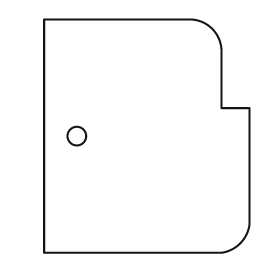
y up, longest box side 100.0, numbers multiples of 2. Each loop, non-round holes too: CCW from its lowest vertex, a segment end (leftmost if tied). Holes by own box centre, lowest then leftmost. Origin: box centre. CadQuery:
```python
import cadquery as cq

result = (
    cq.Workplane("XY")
    .moveTo(-44.0, -50.0)
    .lineTo(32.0, -50.0)
    .threePointArc((40.0, -46.0), (44.0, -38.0))
    .lineTo(44.0, 12.0)
    .lineTo(32.0, 12.0)
    .lineTo(32.0, 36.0)
    .threePointArc((28.0, 46.0), (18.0, 50.0))
    .lineTo(-44.0, 50.0)
    .close()
    .moveTo(-30.0, 0.0)
    .circle(4.0)
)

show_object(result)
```